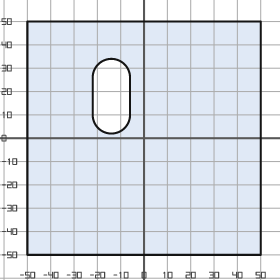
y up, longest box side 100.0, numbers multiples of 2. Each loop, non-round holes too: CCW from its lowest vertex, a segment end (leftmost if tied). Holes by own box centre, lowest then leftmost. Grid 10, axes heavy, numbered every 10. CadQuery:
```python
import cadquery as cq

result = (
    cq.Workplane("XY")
    .moveTo(-50.0, -50.0)
    .lineTo(50.0, -50.0)
    .lineTo(50.0, 50.0)
    .lineTo(-50.0, 50.0)
    .close()
    .moveTo(-22.0, 10.0)
    .threePointArc((-14.0, 2.0), (-6.0, 10.0))
    .lineTo(-6.0, 26.0)
    .threePointArc((-14.0, 34.0), (-22.0, 26.0))
    .close()
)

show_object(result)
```